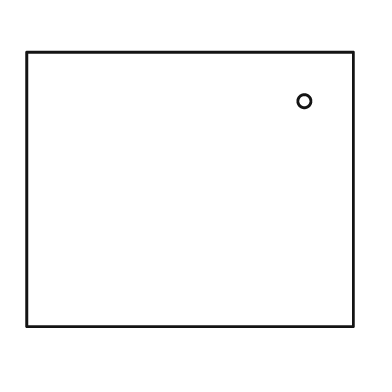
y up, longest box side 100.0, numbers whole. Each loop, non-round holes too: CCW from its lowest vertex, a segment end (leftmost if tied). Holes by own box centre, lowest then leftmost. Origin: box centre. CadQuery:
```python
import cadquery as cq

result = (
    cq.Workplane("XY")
    .moveTo(-50.0, -42.0)
    .lineTo(50.0, -42.0)
    .lineTo(50.0, 42.0)
    .lineTo(-50.0, 42.0)
    .close()
    .moveTo(35.0, 27.0)
    .circle(2.0)
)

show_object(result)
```